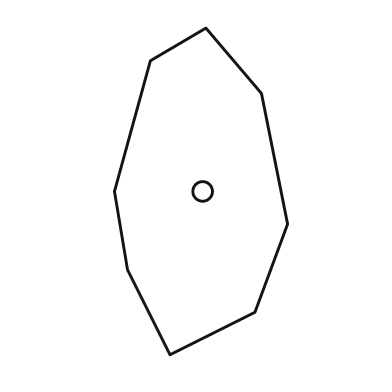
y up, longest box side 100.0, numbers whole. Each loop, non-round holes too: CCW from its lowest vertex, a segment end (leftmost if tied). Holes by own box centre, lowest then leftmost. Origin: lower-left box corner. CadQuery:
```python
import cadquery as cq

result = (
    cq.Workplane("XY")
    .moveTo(17.0, 0.0)
    .lineTo(43.0, 13.0)
    .lineTo(53.0, 40.0)
    .lineTo(45.0, 80.0)
    .lineTo(28.0, 100.0)
    .lineTo(11.0, 90.0)
    .lineTo(0.0, 50.0)
    .lineTo(4.0, 26.0)
    .close()
    .moveTo(27.0, 50.0)
    .circle(3.0)
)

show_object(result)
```